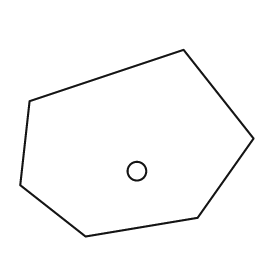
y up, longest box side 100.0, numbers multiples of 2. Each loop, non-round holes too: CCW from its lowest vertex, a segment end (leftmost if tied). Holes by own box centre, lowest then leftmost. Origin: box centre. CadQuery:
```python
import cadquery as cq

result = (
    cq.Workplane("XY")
    .moveTo(-22.0, -40.0)
    .lineTo(26.0, -32.0)
    .lineTo(50.0, 2.0)
    .lineTo(20.0, 40.0)
    .lineTo(-46.0, 18.0)
    .lineTo(-50.0, -18.0)
    .close()
    .moveTo(0.0, -12.0)
    .circle(4.0)
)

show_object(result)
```